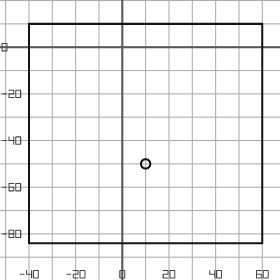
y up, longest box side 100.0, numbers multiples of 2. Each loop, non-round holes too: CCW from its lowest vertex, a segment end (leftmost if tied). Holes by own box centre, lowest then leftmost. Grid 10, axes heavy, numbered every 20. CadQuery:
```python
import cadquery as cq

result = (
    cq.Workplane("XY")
    .moveTo(-40.0, -84.0)
    .lineTo(60.0, -84.0)
    .lineTo(60.0, 10.0)
    .lineTo(-40.0, 10.0)
    .close()
    .moveTo(10.0, -50.0)
    .circle(2.0)
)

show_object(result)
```